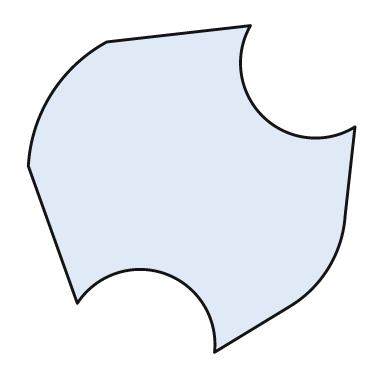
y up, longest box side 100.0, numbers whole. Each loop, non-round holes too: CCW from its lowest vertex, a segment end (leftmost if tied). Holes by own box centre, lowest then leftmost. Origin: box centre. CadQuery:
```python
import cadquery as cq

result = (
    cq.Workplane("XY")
    .moveTo(7.0, -50.0)
    .lineTo(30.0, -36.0)
    .threePointArc((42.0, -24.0), (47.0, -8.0))
    .lineTo(50.0, 19.0)
    .threePointArc((22.0, 22.0), (18.0, 50.0))
    .lineTo(-26.0, 45.0)
    .threePointArc((-43.0, 29.0), (-50.0, 7.0))
    .lineTo(-35.0, -35.0)
    .threePointArc((-8.0, -26.0), (7.0, -50.0))
    .close()
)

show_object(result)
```